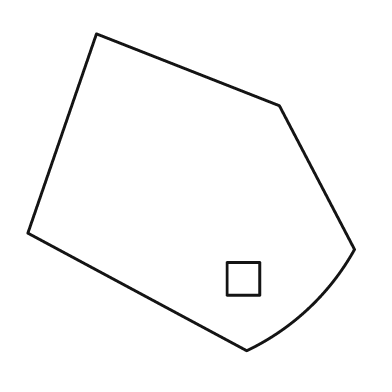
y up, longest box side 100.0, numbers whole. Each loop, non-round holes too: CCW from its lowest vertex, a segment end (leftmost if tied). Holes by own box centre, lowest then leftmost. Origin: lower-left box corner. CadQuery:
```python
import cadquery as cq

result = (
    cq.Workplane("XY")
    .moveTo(67.0, 0.0)
    .threePointArc((86.0, 13.0), (100.0, 31.0))
    .lineTo(77.0, 75.0)
    .lineTo(21.0, 97.0)
    .lineTo(0.0, 36.0)
    .close()
    .moveTo(61.0, 17.0)
    .lineTo(71.0, 17.0)
    .lineTo(71.0, 27.0)
    .lineTo(61.0, 27.0)
    .close()
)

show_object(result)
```